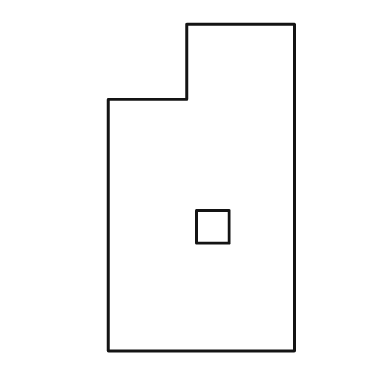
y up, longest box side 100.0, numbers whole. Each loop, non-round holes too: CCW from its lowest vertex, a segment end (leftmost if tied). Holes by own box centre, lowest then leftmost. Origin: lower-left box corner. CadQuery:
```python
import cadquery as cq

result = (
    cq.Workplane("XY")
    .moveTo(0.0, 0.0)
    .lineTo(57.0, 0.0)
    .lineTo(57.0, 100.0)
    .lineTo(24.0, 100.0)
    .lineTo(24.0, 77.0)
    .lineTo(0.0, 77.0)
    .close()
    .moveTo(27.0, 33.0)
    .lineTo(37.0, 33.0)
    .lineTo(37.0, 43.0)
    .lineTo(27.0, 43.0)
    .close()
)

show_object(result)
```